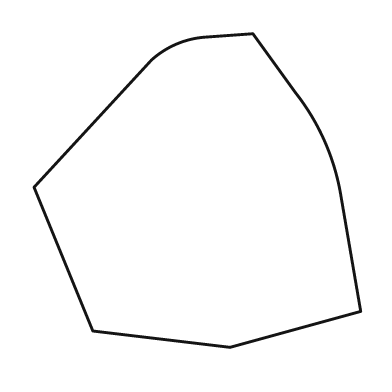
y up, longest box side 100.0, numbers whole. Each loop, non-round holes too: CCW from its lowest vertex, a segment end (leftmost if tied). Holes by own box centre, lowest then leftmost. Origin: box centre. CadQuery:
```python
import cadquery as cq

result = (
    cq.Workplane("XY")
    .moveTo(10.0, -48.0)
    .lineTo(50.0, -37.0)
    .lineTo(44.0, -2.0)
    .threePointArc((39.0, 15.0), (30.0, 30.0))
    .lineTo(17.0, 48.0)
    .lineTo(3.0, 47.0)
    .threePointArc((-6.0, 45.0), (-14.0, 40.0))
    .lineTo(-50.0, 1.0)
    .lineTo(-32.0, -43.0)
    .close()
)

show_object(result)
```